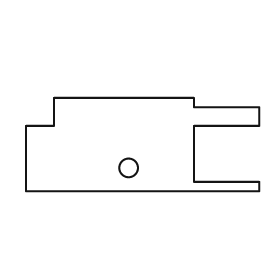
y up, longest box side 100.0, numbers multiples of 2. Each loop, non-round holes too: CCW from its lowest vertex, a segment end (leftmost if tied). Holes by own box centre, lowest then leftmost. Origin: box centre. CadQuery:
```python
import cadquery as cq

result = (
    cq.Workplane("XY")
    .moveTo(-50.0, -20.0)
    .lineTo(50.0, -20.0)
    .lineTo(50.0, -16.0)
    .lineTo(22.0, -16.0)
    .lineTo(22.0, 8.0)
    .lineTo(50.0, 8.0)
    .lineTo(50.0, 16.0)
    .lineTo(22.0, 16.0)
    .lineTo(22.0, 20.0)
    .lineTo(-38.0, 20.0)
    .lineTo(-38.0, 8.0)
    .lineTo(-50.0, 8.0)
    .close()
    .moveTo(-6.0, -10.0)
    .circle(4.0)
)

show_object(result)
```